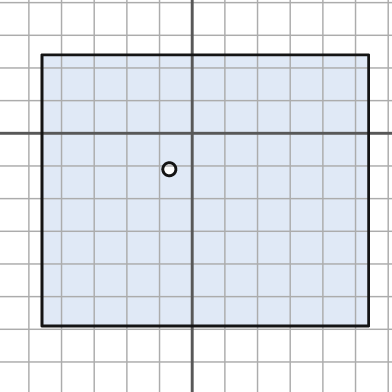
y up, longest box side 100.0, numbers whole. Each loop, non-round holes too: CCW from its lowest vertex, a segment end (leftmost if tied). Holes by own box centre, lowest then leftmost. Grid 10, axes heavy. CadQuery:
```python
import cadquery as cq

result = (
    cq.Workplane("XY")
    .moveTo(-46.0, -59.0)
    .lineTo(54.0, -59.0)
    .lineTo(54.0, 24.0)
    .lineTo(-46.0, 24.0)
    .close()
    .moveTo(-7.0, -11.0)
    .circle(2.0)
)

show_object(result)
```